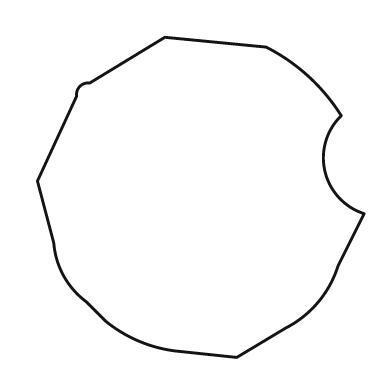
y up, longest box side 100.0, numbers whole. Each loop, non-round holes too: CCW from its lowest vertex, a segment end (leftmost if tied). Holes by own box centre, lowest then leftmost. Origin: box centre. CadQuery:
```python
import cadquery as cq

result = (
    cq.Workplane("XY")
    .moveTo(11.0, -49.0)
    .lineTo(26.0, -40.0)
    .threePointArc((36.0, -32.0), (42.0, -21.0))
    .lineTo(50.0, -5.0)
    .threePointArc((38.0, 8.0), (43.0, 25.0))
    .threePointArc((33.0, 37.0), (20.0, 46.0))
    .lineTo(-11.0, 49.0)
    .lineTo(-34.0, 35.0)
    .threePointArc((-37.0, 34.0), (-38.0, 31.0))
    .lineTo(-50.0, 5.0)
    .lineTo(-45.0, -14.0)
    .threePointArc((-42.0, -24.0), (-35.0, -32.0))
    .lineTo(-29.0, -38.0)
    .threePointArc((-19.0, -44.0), (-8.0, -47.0))
    .close()
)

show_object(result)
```